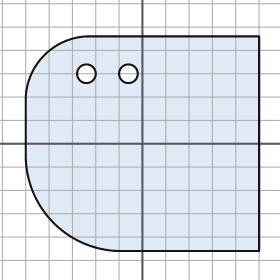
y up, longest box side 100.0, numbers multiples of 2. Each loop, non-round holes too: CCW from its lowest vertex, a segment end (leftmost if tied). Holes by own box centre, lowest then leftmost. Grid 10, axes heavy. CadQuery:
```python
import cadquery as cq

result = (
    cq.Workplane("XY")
    .moveTo(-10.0, -46.0)
    .lineTo(50.0, -46.0)
    .lineTo(50.0, 46.0)
    .lineTo(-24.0, 46.0)
    .threePointArc((-42.0, 38.0), (-50.0, 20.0))
    .lineTo(-50.0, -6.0)
    .threePointArc((-38.0, -34.0), (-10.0, -46.0))
    .close()
    .moveTo(-24.0, 30.0)
    .circle(4.0)
    .moveTo(-6.0, 30.0)
    .circle(4.0)
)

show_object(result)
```